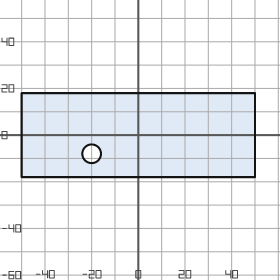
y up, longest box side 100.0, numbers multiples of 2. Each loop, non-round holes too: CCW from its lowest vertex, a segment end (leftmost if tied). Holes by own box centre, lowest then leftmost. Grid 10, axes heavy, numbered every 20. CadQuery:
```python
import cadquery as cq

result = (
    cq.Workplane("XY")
    .moveTo(-50.0, -18.0)
    .lineTo(50.0, -18.0)
    .lineTo(50.0, 18.0)
    .lineTo(-50.0, 18.0)
    .close()
    .moveTo(-20.0, -8.0)
    .circle(4.0)
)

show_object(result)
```